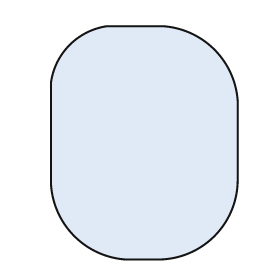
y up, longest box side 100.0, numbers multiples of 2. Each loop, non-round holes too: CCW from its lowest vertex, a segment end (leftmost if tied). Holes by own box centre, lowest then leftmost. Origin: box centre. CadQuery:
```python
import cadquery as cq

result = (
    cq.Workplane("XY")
    .moveTo(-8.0, -50.0)
    .lineTo(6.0, -50.0)
    .threePointArc((30.0, -40.0), (40.0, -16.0))
    .lineTo(40.0, 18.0)
    .threePointArc((30.0, 40.0), (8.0, 50.0))
    .lineTo(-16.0, 50.0)
    .threePointArc((-32.0, 42.0), (-40.0, 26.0))
    .lineTo(-40.0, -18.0)
    .threePointArc((-30.0, -40.0), (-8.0, -50.0))
    .close()
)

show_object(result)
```